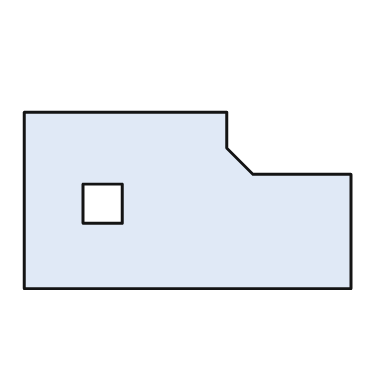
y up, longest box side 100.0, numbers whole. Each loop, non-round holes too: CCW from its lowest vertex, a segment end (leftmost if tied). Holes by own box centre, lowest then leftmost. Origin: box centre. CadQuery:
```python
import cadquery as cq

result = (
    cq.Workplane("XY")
    .moveTo(-50.0, -27.0)
    .lineTo(50.0, -27.0)
    .lineTo(50.0, 8.0)
    .lineTo(20.0, 8.0)
    .lineTo(12.0, 16.0)
    .lineTo(12.0, 27.0)
    .lineTo(-50.0, 27.0)
    .close()
    .moveTo(-32.0, -7.0)
    .lineTo(-20.0, -7.0)
    .lineTo(-20.0, 5.0)
    .lineTo(-32.0, 5.0)
    .close()
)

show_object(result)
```